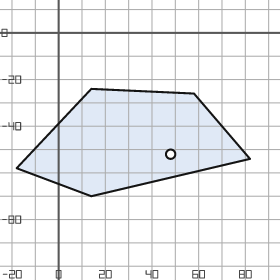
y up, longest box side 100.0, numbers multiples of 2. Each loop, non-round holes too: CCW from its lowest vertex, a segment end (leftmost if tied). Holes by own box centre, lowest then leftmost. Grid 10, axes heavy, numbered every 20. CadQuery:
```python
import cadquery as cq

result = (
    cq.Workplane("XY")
    .moveTo(14.0, -70.0)
    .lineTo(82.0, -54.0)
    .lineTo(58.0, -26.0)
    .lineTo(14.0, -24.0)
    .lineTo(-18.0, -58.0)
    .close()
    .moveTo(48.0, -52.0)
    .circle(2.0)
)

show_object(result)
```